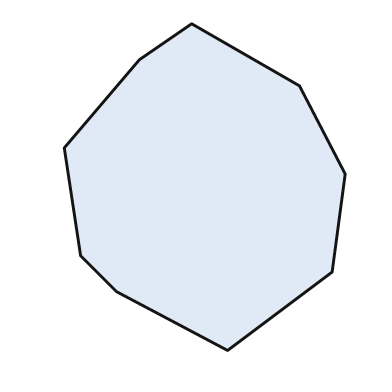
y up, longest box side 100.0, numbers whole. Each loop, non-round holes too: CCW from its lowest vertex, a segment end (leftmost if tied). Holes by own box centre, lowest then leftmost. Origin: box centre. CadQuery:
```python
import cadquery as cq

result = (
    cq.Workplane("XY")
    .moveTo(7.0, -50.0)
    .lineTo(39.0, -26.0)
    .lineTo(43.0, 4.0)
    .lineTo(29.0, 31.0)
    .lineTo(-4.0, 50.0)
    .lineTo(-20.0, 39.0)
    .lineTo(-43.0, 12.0)
    .lineTo(-38.0, -21.0)
    .lineTo(-27.0, -32.0)
    .close()
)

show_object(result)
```